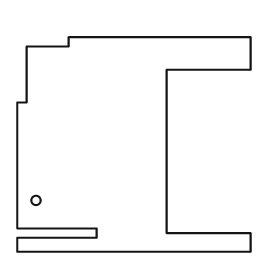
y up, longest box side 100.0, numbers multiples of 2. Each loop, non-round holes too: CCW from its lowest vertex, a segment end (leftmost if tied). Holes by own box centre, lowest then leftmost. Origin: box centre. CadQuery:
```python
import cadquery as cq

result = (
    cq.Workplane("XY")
    .moveTo(-50.0, -46.0)
    .lineTo(50.0, -46.0)
    .lineTo(50.0, -38.0)
    .lineTo(14.0, -38.0)
    .lineTo(14.0, 32.0)
    .lineTo(50.0, 32.0)
    .lineTo(50.0, 46.0)
    .lineTo(-28.0, 46.0)
    .lineTo(-28.0, 42.0)
    .lineTo(-46.0, 42.0)
    .lineTo(-46.0, 18.0)
    .lineTo(-50.0, 18.0)
    .lineTo(-50.0, -36.0)
    .lineTo(-16.0, -36.0)
    .lineTo(-16.0, -40.0)
    .lineTo(-50.0, -40.0)
    .close()
    .moveTo(-42.0, -24.0)
    .circle(2.0)
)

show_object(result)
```